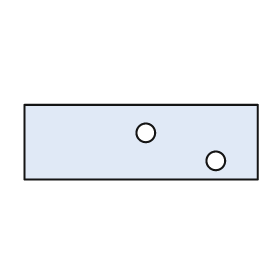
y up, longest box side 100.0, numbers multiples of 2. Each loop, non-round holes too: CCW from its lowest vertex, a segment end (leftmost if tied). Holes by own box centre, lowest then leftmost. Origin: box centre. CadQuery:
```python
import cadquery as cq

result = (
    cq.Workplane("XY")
    .moveTo(-50.0, -16.0)
    .lineTo(50.0, -16.0)
    .lineTo(50.0, 16.0)
    .lineTo(-50.0, 16.0)
    .close()
    .moveTo(32.0, -8.0)
    .circle(4.0)
    .moveTo(2.0, 4.0)
    .circle(4.0)
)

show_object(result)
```